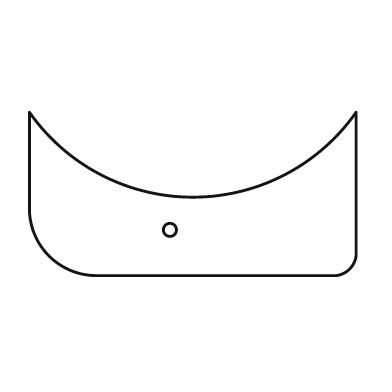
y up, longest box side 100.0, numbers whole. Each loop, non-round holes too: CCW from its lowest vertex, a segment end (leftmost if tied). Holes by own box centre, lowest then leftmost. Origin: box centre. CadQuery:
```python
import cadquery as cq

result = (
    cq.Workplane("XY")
    .moveTo(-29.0, -25.0)
    .lineTo(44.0, -25.0)
    .threePointArc((48.0, -23.0), (50.0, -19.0))
    .lineTo(50.0, 25.0)
    .threePointArc((0.0, -1.0), (-50.0, 25.0))
    .lineTo(-50.0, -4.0)
    .threePointArc((-44.0, -19.0), (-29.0, -25.0))
    .close()
    .moveTo(-7.0, -11.0)
    .circle(2.0)
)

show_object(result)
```